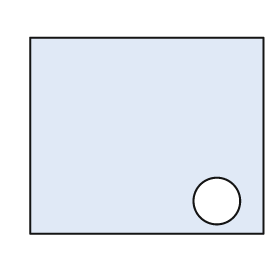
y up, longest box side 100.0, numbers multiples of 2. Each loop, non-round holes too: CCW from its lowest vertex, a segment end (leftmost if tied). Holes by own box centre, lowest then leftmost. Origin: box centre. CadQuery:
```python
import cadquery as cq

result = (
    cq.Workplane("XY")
    .moveTo(-50.0, -42.0)
    .lineTo(50.0, -42.0)
    .lineTo(50.0, 42.0)
    .lineTo(-50.0, 42.0)
    .close()
    .moveTo(30.0, -28.0)
    .circle(10.0)
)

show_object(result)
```